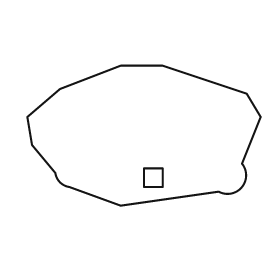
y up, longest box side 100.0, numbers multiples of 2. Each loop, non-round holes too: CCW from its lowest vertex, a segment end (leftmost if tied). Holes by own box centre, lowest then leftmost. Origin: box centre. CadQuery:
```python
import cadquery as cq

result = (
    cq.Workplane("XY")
    .moveTo(-10.0, -30.0)
    .lineTo(32.0, -24.0)
    .threePointArc((42.0, -22.0), (42.0, -12.0))
    .lineTo(50.0, 8.0)
    .lineTo(44.0, 18.0)
    .lineTo(8.0, 30.0)
    .lineTo(-10.0, 30.0)
    .lineTo(-36.0, 20.0)
    .lineTo(-50.0, 8.0)
    .lineTo(-48.0, -4.0)
    .lineTo(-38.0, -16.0)
    .threePointArc((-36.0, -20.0), (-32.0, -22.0))
    .close()
    .moveTo(0.0, -22.0)
    .lineTo(8.0, -22.0)
    .lineTo(8.0, -14.0)
    .lineTo(0.0, -14.0)
    .close()
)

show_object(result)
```